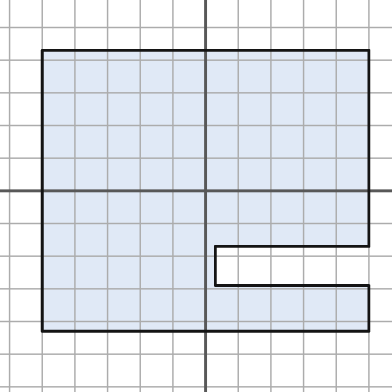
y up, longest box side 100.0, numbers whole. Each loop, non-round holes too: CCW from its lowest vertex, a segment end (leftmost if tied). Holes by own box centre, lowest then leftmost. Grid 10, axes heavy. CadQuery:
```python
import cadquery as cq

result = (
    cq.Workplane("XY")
    .moveTo(-50.0, -43.0)
    .lineTo(50.0, -43.0)
    .lineTo(50.0, -29.0)
    .lineTo(3.0, -29.0)
    .lineTo(3.0, -17.0)
    .lineTo(50.0, -17.0)
    .lineTo(50.0, 43.0)
    .lineTo(-50.0, 43.0)
    .close()
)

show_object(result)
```